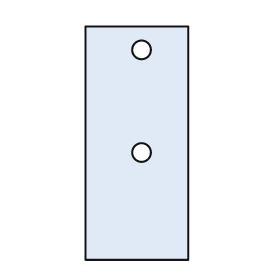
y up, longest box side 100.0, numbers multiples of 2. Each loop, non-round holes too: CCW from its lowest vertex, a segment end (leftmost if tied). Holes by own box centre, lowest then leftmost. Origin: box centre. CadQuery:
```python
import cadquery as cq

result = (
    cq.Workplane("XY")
    .moveTo(-22.0, -50.0)
    .lineTo(22.0, -50.0)
    .lineTo(22.0, 50.0)
    .lineTo(-22.0, 50.0)
    .close()
    .moveTo(2.0, -4.0)
    .circle(4.0)
    .moveTo(2.0, 40.0)
    .circle(4.0)
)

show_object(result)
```